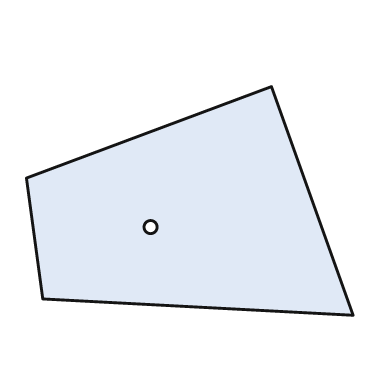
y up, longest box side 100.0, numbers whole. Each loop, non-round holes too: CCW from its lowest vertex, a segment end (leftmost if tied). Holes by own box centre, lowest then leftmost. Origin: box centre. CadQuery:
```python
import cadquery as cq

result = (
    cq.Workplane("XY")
    .moveTo(50.0, -35.0)
    .lineTo(25.0, 35.0)
    .lineTo(-50.0, 7.0)
    .lineTo(-45.0, -30.0)
    .close()
    .moveTo(-12.0, -8.0)
    .circle(2.0)
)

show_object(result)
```